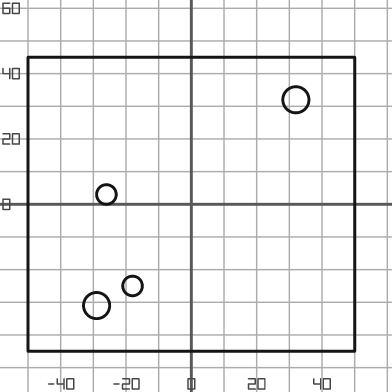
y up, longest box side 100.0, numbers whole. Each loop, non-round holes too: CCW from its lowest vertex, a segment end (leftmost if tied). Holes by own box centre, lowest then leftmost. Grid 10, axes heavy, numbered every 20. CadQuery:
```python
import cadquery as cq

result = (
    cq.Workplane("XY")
    .moveTo(-50.0, -45.0)
    .lineTo(50.0, -45.0)
    .lineTo(50.0, 45.0)
    .lineTo(-50.0, 45.0)
    .close()
    .moveTo(-29.0, -31.0)
    .circle(4.0)
    .moveTo(-18.0, -25.0)
    .circle(3.0)
    .moveTo(-26.0, 3.0)
    .circle(3.0)
    .moveTo(32.0, 32.0)
    .circle(4.0)
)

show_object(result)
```